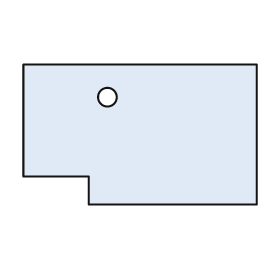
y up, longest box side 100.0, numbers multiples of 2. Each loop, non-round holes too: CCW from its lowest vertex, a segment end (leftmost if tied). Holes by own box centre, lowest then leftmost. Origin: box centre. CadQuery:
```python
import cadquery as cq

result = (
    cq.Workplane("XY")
    .moveTo(-22.0, -30.0)
    .lineTo(50.0, -30.0)
    .lineTo(50.0, 30.0)
    .lineTo(-50.0, 30.0)
    .lineTo(-50.0, -18.0)
    .lineTo(-22.0, -18.0)
    .close()
    .moveTo(-14.0, 16.0)
    .circle(4.0)
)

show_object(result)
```